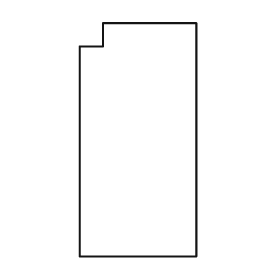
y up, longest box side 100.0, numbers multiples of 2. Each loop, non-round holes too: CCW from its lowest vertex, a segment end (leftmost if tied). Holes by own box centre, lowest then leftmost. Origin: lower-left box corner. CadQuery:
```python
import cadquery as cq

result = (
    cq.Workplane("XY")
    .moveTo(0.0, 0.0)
    .lineTo(50.0, 0.0)
    .lineTo(50.0, 100.0)
    .lineTo(10.0, 100.0)
    .lineTo(10.0, 90.0)
    .lineTo(0.0, 90.0)
    .close()
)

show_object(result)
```